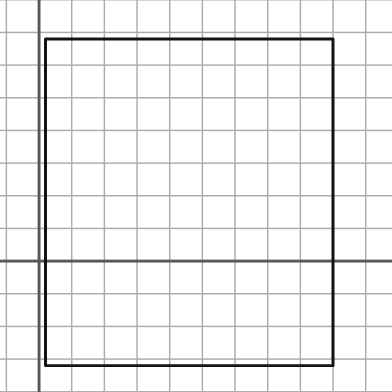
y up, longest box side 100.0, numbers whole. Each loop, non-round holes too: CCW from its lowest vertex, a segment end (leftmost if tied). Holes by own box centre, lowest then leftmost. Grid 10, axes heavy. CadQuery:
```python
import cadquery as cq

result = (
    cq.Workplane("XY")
    .moveTo(2.0, -32.0)
    .lineTo(90.0, -32.0)
    .lineTo(90.0, 68.0)
    .lineTo(2.0, 68.0)
    .close()
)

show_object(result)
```